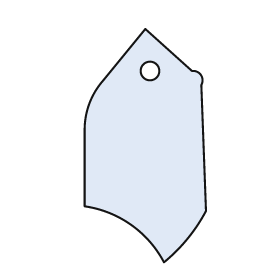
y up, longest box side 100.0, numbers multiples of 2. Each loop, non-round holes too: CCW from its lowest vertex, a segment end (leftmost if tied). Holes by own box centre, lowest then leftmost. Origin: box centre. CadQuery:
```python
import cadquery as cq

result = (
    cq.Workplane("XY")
    .moveTo(8.0, -50.0)
    .threePointArc((18.0, -40.0), (26.0, -28.0))
    .lineTo(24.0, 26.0)
    .threePointArc((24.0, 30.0), (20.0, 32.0))
    .lineTo(0.0, 50.0)
    .lineTo(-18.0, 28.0)
    .threePointArc((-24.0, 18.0), (-26.0, 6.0))
    .lineTo(-26.0, -26.0)
    .threePointArc((-6.0, -34.0), (8.0, -50.0))
    .close()
    .moveTo(2.0, 32.0)
    .circle(4.0)
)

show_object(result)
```